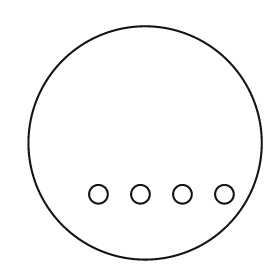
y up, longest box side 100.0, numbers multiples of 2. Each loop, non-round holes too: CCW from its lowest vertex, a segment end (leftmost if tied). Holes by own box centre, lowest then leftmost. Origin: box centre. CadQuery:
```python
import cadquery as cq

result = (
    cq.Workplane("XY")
    .moveTo(0.0, 0.0)
    .circle(50.0)
    .moveTo(-20.0, -22.0)
    .circle(4.0)
    .moveTo(-2.0, -22.0)
    .circle(4.0)
    .moveTo(16.0, -22.0)
    .circle(4.0)
    .moveTo(34.0, -22.0)
    .circle(4.0)
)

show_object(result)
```